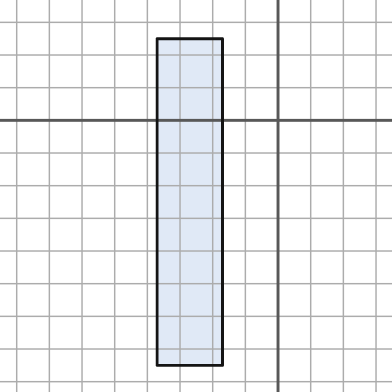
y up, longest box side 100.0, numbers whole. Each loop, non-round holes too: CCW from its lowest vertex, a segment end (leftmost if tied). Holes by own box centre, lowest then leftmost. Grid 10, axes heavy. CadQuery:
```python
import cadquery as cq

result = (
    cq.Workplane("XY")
    .moveTo(-37.0, -75.0)
    .lineTo(-17.0, -75.0)
    .lineTo(-17.0, 25.0)
    .lineTo(-37.0, 25.0)
    .close()
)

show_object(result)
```